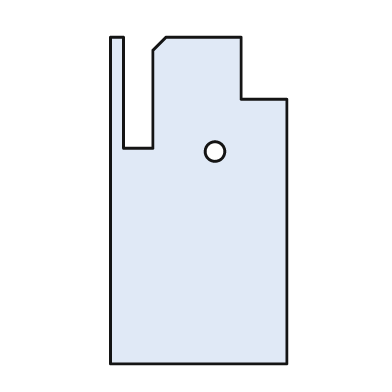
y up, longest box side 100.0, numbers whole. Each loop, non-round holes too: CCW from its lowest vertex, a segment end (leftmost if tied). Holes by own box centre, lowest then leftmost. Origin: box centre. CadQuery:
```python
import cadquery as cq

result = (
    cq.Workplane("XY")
    .moveTo(-27.0, -50.0)
    .lineTo(27.0, -50.0)
    .lineTo(27.0, 31.0)
    .lineTo(13.0, 31.0)
    .lineTo(13.0, 50.0)
    .lineTo(-10.0, 50.0)
    .lineTo(-14.0, 46.0)
    .lineTo(-14.0, 16.0)
    .lineTo(-23.0, 16.0)
    .lineTo(-23.0, 50.0)
    .lineTo(-27.0, 50.0)
    .close()
    .moveTo(5.0, 15.0)
    .circle(3.0)
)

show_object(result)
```